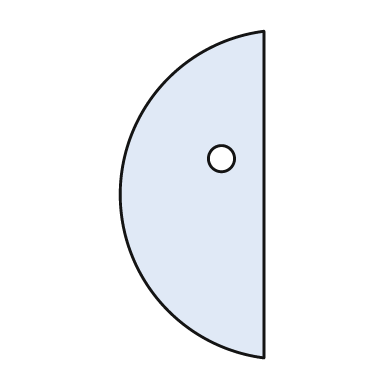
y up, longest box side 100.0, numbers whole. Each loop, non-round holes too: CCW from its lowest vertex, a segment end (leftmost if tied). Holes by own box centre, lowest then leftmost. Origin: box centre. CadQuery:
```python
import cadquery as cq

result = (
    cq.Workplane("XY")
    .moveTo(22.0, -50.0)
    .lineTo(22.0, 50.0)
    .threePointArc((-22.0, 0.0), (22.0, -50.0))
    .close()
    .moveTo(9.0, 11.0)
    .circle(4.0)
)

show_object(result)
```